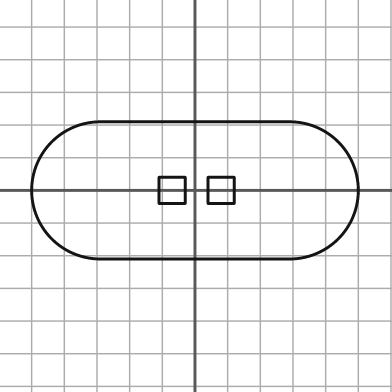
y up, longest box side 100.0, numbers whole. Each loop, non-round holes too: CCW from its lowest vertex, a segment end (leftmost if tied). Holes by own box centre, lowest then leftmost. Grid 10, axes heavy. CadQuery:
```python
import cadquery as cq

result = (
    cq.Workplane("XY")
    .moveTo(-29.0, -21.0)
    .lineTo(29.0, -21.0)
    .threePointArc((50.0, 0.0), (29.0, 21.0))
    .lineTo(-29.0, 21.0)
    .threePointArc((-50.0, 0.0), (-29.0, -21.0))
    .close()
    .moveTo(-11.0, -4.0)
    .lineTo(-3.0, -4.0)
    .lineTo(-3.0, 4.0)
    .lineTo(-11.0, 4.0)
    .close()
    .moveTo(4.0, -4.0)
    .lineTo(12.0, -4.0)
    .lineTo(12.0, 4.0)
    .lineTo(4.0, 4.0)
    .close()
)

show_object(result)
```